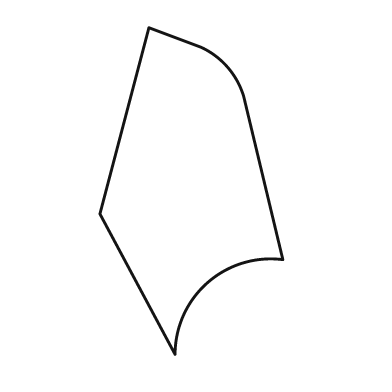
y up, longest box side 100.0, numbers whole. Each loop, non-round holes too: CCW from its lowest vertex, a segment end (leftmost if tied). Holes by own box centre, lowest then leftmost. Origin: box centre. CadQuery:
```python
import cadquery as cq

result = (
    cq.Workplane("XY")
    .moveTo(-5.0, -50.0)
    .threePointArc((5.0, -28.0), (28.0, -21.0))
    .lineTo(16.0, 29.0)
    .threePointArc((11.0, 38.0), (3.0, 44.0))
    .lineTo(-13.0, 50.0)
    .lineTo(-28.0, -7.0)
    .close()
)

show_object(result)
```